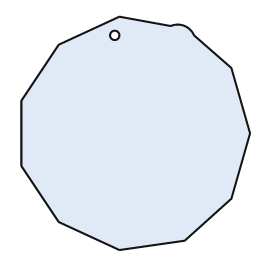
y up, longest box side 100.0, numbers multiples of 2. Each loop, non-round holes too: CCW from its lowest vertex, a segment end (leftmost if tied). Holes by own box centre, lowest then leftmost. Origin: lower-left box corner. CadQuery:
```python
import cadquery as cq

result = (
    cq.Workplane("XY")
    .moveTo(42.0, 0.0)
    .lineTo(70.0, 4.0)
    .lineTo(90.0, 22.0)
    .lineTo(98.0, 50.0)
    .lineTo(90.0, 78.0)
    .lineTo(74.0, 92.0)
    .threePointArc((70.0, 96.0), (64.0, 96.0))
    .lineTo(42.0, 100.0)
    .lineTo(16.0, 88.0)
    .lineTo(0.0, 64.0)
    .lineTo(0.0, 36.0)
    .lineTo(16.0, 12.0)
    .close()
    .moveTo(40.0, 92.0)
    .circle(2.0)
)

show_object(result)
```